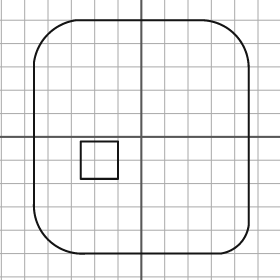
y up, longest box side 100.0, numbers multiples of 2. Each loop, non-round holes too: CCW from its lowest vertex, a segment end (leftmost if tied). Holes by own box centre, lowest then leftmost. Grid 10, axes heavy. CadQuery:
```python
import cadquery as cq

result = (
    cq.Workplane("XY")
    .moveTo(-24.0, -50.0)
    .lineTo(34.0, -50.0)
    .threePointArc((42.0, -46.0), (46.0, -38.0))
    .lineTo(46.0, 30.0)
    .threePointArc((40.0, 44.0), (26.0, 50.0))
    .lineTo(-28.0, 50.0)
    .threePointArc((-40.0, 44.0), (-46.0, 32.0))
    .lineTo(-46.0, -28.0)
    .threePointArc((-40.0, -44.0), (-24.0, -50.0))
    .close()
    .moveTo(-26.0, -18.0)
    .lineTo(-10.0, -18.0)
    .lineTo(-10.0, -2.0)
    .lineTo(-26.0, -2.0)
    .close()
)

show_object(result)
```